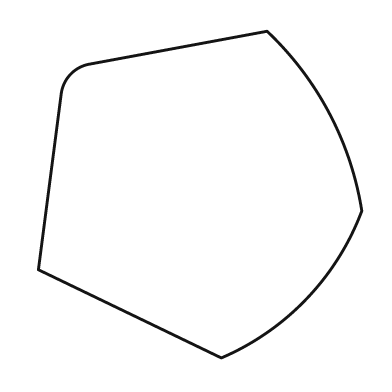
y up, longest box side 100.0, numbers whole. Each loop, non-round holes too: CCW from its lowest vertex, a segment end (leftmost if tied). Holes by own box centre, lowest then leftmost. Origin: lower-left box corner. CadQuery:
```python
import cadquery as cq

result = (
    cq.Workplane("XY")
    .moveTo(56.0, 0.0)
    .threePointArc((82.0, 18.0), (99.0, 45.0))
    .threePointArc((89.0, 75.0), (70.0, 100.0))
    .lineTo(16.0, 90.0)
    .threePointArc((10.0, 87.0), (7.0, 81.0))
    .lineTo(0.0, 27.0)
    .close()
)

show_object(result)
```